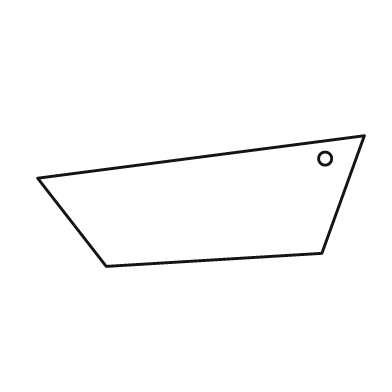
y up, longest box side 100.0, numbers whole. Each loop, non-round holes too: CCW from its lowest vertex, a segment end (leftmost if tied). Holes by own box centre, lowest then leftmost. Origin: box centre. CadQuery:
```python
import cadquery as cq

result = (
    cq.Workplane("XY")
    .moveTo(-29.0, -20.0)
    .lineTo(37.0, -16.0)
    .lineTo(50.0, 20.0)
    .lineTo(-50.0, 7.0)
    .close()
    .moveTo(38.0, 13.0)
    .circle(2.0)
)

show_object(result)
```